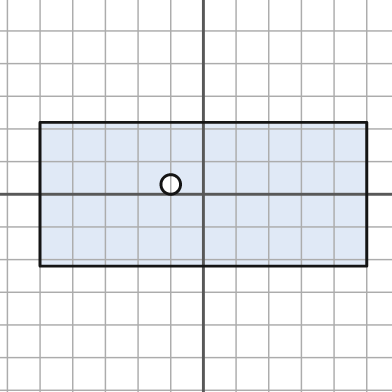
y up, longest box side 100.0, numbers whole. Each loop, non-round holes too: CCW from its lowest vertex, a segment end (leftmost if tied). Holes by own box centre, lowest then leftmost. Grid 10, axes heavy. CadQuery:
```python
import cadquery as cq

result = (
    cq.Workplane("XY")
    .moveTo(-50.0, -22.0)
    .lineTo(50.0, -22.0)
    .lineTo(50.0, 22.0)
    .lineTo(-50.0, 22.0)
    .close()
    .moveTo(-10.0, 3.0)
    .circle(3.0)
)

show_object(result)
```